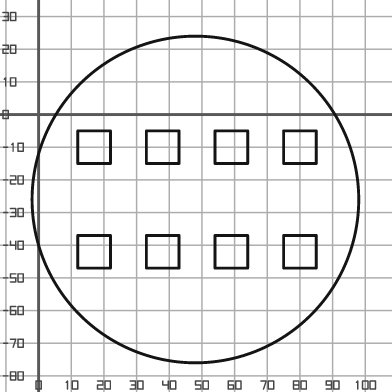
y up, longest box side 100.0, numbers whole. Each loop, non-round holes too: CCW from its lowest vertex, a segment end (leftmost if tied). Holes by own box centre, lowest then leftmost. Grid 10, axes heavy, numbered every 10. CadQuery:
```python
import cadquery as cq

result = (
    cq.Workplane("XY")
    .moveTo(48.0, -26.0)
    .circle(50.0)
    .moveTo(12.0, -47.0)
    .lineTo(22.0, -47.0)
    .lineTo(22.0, -37.0)
    .lineTo(12.0, -37.0)
    .close()
    .moveTo(33.0, -47.0)
    .lineTo(43.0, -47.0)
    .lineTo(43.0, -37.0)
    .lineTo(33.0, -37.0)
    .close()
    .moveTo(54.0, -47.0)
    .lineTo(64.0, -47.0)
    .lineTo(64.0, -37.0)
    .lineTo(54.0, -37.0)
    .close()
    .moveTo(75.0, -47.0)
    .lineTo(85.0, -47.0)
    .lineTo(85.0, -37.0)
    .lineTo(75.0, -37.0)
    .close()
    .moveTo(12.0, -15.0)
    .lineTo(22.0, -15.0)
    .lineTo(22.0, -5.0)
    .lineTo(12.0, -5.0)
    .close()
    .moveTo(33.0, -15.0)
    .lineTo(43.0, -15.0)
    .lineTo(43.0, -5.0)
    .lineTo(33.0, -5.0)
    .close()
    .moveTo(54.0, -15.0)
    .lineTo(64.0, -15.0)
    .lineTo(64.0, -5.0)
    .lineTo(54.0, -5.0)
    .close()
    .moveTo(75.0, -15.0)
    .lineTo(85.0, -15.0)
    .lineTo(85.0, -5.0)
    .lineTo(75.0, -5.0)
    .close()
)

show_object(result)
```